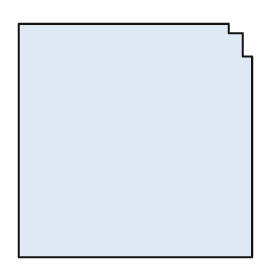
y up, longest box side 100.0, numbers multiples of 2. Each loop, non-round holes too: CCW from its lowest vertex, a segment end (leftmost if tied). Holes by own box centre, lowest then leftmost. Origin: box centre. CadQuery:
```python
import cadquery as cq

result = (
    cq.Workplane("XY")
    .moveTo(-50.0, -50.0)
    .lineTo(50.0, -50.0)
    .lineTo(50.0, 36.0)
    .lineTo(46.0, 36.0)
    .lineTo(46.0, 46.0)
    .lineTo(40.0, 46.0)
    .lineTo(40.0, 50.0)
    .lineTo(-50.0, 50.0)
    .close()
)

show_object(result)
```